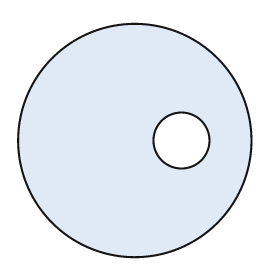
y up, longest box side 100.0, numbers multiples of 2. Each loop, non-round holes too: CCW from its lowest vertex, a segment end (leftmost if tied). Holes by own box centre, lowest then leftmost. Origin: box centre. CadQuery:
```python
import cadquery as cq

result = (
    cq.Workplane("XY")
    .moveTo(0.0, 0.0)
    .circle(50.0)
    .moveTo(20.0, 0.0)
    .circle(12.0)
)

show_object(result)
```